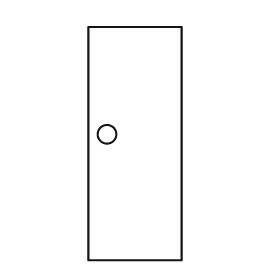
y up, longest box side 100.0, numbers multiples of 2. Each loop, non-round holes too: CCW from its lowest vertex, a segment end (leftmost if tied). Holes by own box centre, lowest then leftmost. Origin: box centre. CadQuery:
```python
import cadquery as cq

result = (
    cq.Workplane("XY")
    .moveTo(-20.0, -50.0)
    .lineTo(20.0, -50.0)
    .lineTo(20.0, 50.0)
    .lineTo(-20.0, 50.0)
    .close()
    .moveTo(-12.0, 4.0)
    .circle(4.0)
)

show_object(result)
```